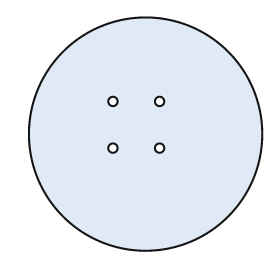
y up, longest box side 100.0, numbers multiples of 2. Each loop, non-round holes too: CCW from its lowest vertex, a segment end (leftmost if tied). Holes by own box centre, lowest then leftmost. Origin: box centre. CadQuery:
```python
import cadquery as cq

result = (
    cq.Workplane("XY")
    .moveTo(0.0, 0.0)
    .circle(50.0)
    .moveTo(-14.0, -6.0)
    .circle(2.0)
    .moveTo(6.0, -6.0)
    .circle(2.0)
    .moveTo(-14.0, 14.0)
    .circle(2.0)
    .moveTo(6.0, 14.0)
    .circle(2.0)
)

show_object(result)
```